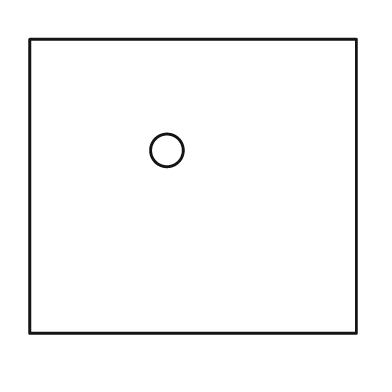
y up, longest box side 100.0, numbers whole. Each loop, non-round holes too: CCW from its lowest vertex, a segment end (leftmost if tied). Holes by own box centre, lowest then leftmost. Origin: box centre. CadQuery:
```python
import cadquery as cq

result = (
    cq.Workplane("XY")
    .moveTo(-50.0, -45.0)
    .lineTo(50.0, -45.0)
    .lineTo(50.0, 45.0)
    .lineTo(-50.0, 45.0)
    .close()
    .moveTo(-8.0, 11.0)
    .circle(5.0)
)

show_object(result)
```